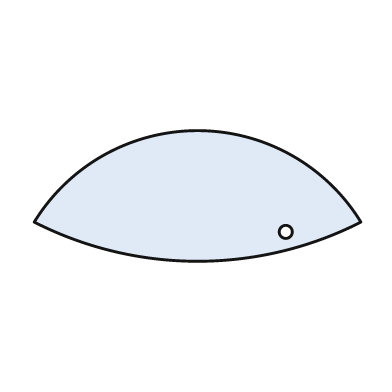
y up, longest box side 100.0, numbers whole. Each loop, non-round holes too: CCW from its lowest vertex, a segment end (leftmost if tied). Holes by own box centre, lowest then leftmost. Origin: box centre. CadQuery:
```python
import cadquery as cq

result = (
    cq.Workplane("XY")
    .moveTo(-50.0, -8.0)
    .threePointArc((0.0, -20.0), (50.0, -8.0))
    .threePointArc((0.0, 20.0), (-50.0, -8.0))
    .close()
    .moveTo(27.0, -11.0)
    .circle(2.0)
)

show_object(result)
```